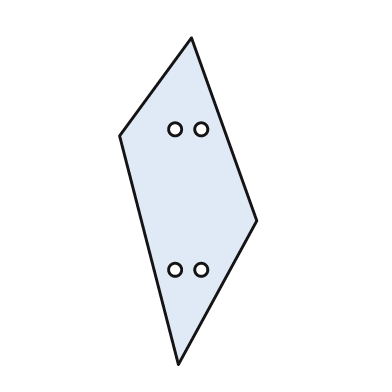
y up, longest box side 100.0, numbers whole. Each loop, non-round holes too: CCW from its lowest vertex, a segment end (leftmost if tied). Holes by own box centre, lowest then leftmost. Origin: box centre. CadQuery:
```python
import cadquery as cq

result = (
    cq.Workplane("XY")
    .moveTo(-3.0, -50.0)
    .lineTo(21.0, -6.0)
    .lineTo(1.0, 50.0)
    .lineTo(-21.0, 20.0)
    .close()
    .moveTo(-4.0, -21.0)
    .circle(2.0)
    .moveTo(4.0, -21.0)
    .circle(2.0)
    .moveTo(-4.0, 22.0)
    .circle(2.0)
    .moveTo(4.0, 22.0)
    .circle(2.0)
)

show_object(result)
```